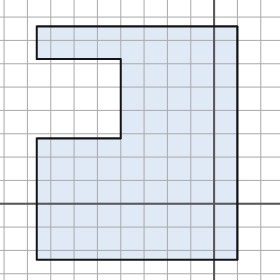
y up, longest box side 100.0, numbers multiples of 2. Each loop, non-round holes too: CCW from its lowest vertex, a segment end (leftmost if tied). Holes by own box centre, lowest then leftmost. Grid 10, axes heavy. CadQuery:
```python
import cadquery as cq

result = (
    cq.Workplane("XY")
    .moveTo(-76.0, -24.0)
    .lineTo(10.0, -24.0)
    .lineTo(10.0, 76.0)
    .lineTo(-76.0, 76.0)
    .lineTo(-76.0, 62.0)
    .lineTo(-40.0, 62.0)
    .lineTo(-40.0, 28.0)
    .lineTo(-76.0, 28.0)
    .close()
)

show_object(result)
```